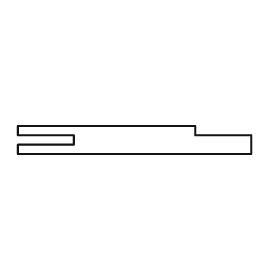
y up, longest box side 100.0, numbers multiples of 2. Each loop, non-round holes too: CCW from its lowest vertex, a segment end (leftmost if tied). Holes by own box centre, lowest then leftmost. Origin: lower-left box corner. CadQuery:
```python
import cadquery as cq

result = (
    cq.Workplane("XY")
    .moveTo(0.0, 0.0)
    .lineTo(100.0, 0.0)
    .lineTo(100.0, 8.0)
    .lineTo(76.0, 8.0)
    .lineTo(76.0, 12.0)
    .lineTo(0.0, 12.0)
    .lineTo(0.0, 8.0)
    .lineTo(24.0, 8.0)
    .lineTo(24.0, 4.0)
    .lineTo(0.0, 4.0)
    .close()
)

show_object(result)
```